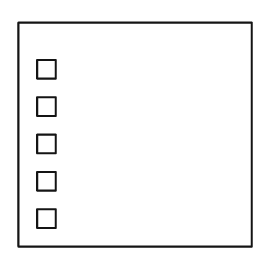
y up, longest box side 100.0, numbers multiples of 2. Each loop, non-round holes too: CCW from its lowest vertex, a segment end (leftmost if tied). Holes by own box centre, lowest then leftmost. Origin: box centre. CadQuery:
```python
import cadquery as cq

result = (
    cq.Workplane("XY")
    .moveTo(-50.0, -48.0)
    .lineTo(50.0, -48.0)
    .lineTo(50.0, 48.0)
    .lineTo(-50.0, 48.0)
    .close()
    .moveTo(-42.0, -40.0)
    .lineTo(-34.0, -40.0)
    .lineTo(-34.0, -32.0)
    .lineTo(-42.0, -32.0)
    .close()
    .moveTo(-42.0, -24.0)
    .lineTo(-34.0, -24.0)
    .lineTo(-34.0, -16.0)
    .lineTo(-42.0, -16.0)
    .close()
    .moveTo(-42.0, -8.0)
    .lineTo(-34.0, -8.0)
    .lineTo(-34.0, 0.0)
    .lineTo(-42.0, 0.0)
    .close()
    .moveTo(-42.0, 8.0)
    .lineTo(-34.0, 8.0)
    .lineTo(-34.0, 16.0)
    .lineTo(-42.0, 16.0)
    .close()
    .moveTo(-42.0, 24.0)
    .lineTo(-34.0, 24.0)
    .lineTo(-34.0, 32.0)
    .lineTo(-42.0, 32.0)
    .close()
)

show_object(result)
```